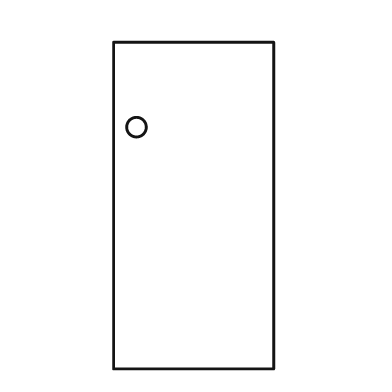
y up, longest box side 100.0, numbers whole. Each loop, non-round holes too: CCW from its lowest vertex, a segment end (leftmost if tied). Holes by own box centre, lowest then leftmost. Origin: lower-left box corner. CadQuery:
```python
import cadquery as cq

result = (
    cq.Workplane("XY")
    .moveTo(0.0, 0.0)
    .lineTo(49.0, 0.0)
    .lineTo(49.0, 100.0)
    .lineTo(0.0, 100.0)
    .close()
    .moveTo(7.0, 74.0)
    .circle(3.0)
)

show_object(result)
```